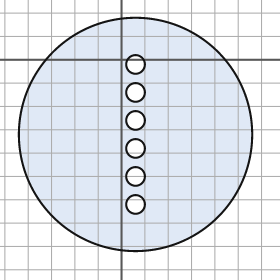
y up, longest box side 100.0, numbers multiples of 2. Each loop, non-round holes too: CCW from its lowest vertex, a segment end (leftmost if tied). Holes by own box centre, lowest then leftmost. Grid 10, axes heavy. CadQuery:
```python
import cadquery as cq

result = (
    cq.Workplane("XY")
    .moveTo(6.0, -32.0)
    .circle(50.0)
    .moveTo(6.0, -62.0)
    .circle(4.0)
    .moveTo(6.0, -50.0)
    .circle(4.0)
    .moveTo(6.0, -38.0)
    .circle(4.0)
    .moveTo(6.0, -26.0)
    .circle(4.0)
    .moveTo(6.0, -14.0)
    .circle(4.0)
    .moveTo(6.0, -2.0)
    .circle(4.0)
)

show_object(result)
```